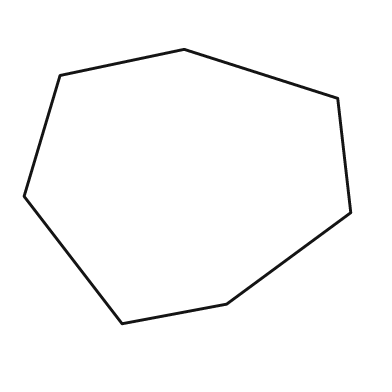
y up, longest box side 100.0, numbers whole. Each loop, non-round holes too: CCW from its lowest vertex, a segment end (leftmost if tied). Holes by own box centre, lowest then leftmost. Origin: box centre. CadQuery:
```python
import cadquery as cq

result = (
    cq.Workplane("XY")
    .moveTo(-20.0, -42.0)
    .lineTo(12.0, -36.0)
    .lineTo(50.0, -8.0)
    .lineTo(46.0, 27.0)
    .lineTo(-1.0, 42.0)
    .lineTo(-39.0, 34.0)
    .lineTo(-50.0, -3.0)
    .close()
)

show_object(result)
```